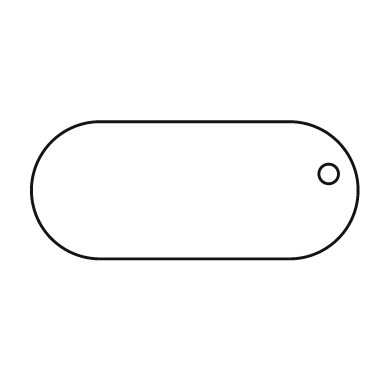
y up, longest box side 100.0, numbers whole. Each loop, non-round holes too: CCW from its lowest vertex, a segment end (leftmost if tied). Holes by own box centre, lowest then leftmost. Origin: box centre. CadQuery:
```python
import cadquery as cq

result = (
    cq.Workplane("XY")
    .moveTo(-29.0, -21.0)
    .lineTo(29.0, -21.0)
    .threePointArc((50.0, 0.0), (29.0, 21.0))
    .lineTo(-29.0, 21.0)
    .threePointArc((-50.0, 0.0), (-29.0, -21.0))
    .close()
    .moveTo(41.0, 5.0)
    .circle(3.0)
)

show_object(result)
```